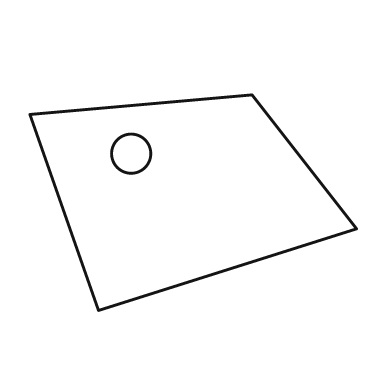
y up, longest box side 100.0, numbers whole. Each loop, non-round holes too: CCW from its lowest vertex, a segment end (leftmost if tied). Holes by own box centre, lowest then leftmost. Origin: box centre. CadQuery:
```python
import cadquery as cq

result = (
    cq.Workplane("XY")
    .moveTo(-29.0, -33.0)
    .lineTo(50.0, -8.0)
    .lineTo(18.0, 33.0)
    .lineTo(-50.0, 27.0)
    .close()
    .moveTo(-19.0, 15.0)
    .circle(6.0)
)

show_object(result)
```